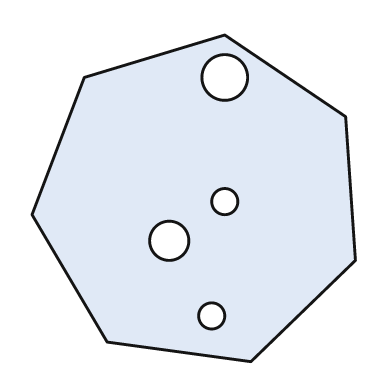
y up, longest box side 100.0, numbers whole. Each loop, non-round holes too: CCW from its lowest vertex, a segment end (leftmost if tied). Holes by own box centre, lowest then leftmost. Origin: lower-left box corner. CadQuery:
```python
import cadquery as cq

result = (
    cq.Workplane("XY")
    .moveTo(67.0, 0.0)
    .lineTo(99.0, 31.0)
    .lineTo(96.0, 75.0)
    .lineTo(59.0, 100.0)
    .lineTo(16.0, 87.0)
    .lineTo(0.0, 45.0)
    .lineTo(23.0, 6.0)
    .close()
    .moveTo(55.0, 14.0)
    .circle(4.0)
    .moveTo(42.0, 37.0)
    .circle(6.0)
    .moveTo(59.0, 49.0)
    .circle(4.0)
    .moveTo(59.0, 87.0)
    .circle(7.0)
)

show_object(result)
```